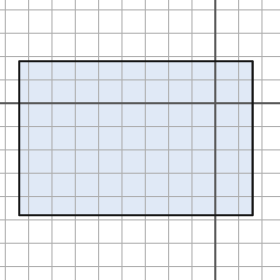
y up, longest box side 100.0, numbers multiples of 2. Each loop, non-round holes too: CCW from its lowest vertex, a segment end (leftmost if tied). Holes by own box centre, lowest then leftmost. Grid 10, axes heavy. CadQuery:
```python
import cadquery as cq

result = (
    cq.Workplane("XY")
    .moveTo(-84.0, -48.0)
    .lineTo(16.0, -48.0)
    .lineTo(16.0, 18.0)
    .lineTo(-84.0, 18.0)
    .close()
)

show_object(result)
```